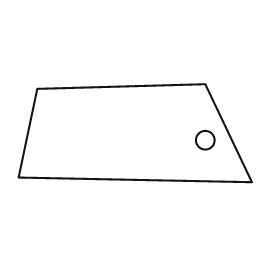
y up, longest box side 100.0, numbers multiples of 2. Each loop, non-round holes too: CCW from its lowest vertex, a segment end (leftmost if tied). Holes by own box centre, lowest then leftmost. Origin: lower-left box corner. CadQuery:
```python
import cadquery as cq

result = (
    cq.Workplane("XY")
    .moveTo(100.0, 0.0)
    .lineTo(80.0, 42.0)
    .lineTo(8.0, 40.0)
    .lineTo(0.0, 2.0)
    .close()
    .moveTo(80.0, 18.0)
    .circle(4.0)
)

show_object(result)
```